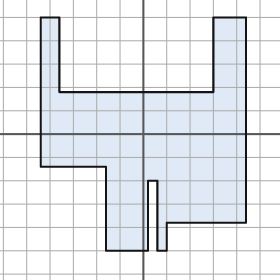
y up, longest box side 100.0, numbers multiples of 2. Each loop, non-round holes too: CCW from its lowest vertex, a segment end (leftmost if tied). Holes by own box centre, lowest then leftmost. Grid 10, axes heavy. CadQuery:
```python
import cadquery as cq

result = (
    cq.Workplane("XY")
    .moveTo(-16.0, -50.0)
    .lineTo(2.0, -50.0)
    .lineTo(2.0, -20.0)
    .lineTo(6.0, -20.0)
    .lineTo(6.0, -50.0)
    .lineTo(10.0, -50.0)
    .lineTo(10.0, -38.0)
    .lineTo(44.0, -38.0)
    .lineTo(44.0, 50.0)
    .lineTo(30.0, 50.0)
    .lineTo(30.0, 18.0)
    .lineTo(-36.0, 18.0)
    .lineTo(-36.0, 50.0)
    .lineTo(-44.0, 50.0)
    .lineTo(-44.0, -14.0)
    .lineTo(-16.0, -14.0)
    .close()
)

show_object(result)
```